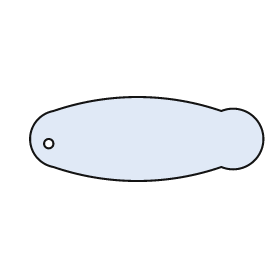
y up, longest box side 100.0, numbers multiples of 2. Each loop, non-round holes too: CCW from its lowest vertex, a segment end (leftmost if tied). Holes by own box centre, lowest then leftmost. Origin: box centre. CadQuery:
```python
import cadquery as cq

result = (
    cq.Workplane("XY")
    .moveTo(-40.0, -12.0)
    .threePointArc((-4.0, -18.0), (32.0, -12.0))
    .threePointArc((50.0, 0.0), (32.0, 12.0))
    .threePointArc((-4.0, 18.0), (-40.0, 12.0))
    .threePointArc((-50.0, 0.0), (-40.0, -12.0))
    .close()
    .moveTo(-42.0, -2.0)
    .circle(2.0)
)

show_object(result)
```